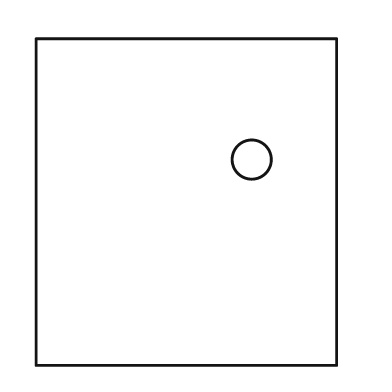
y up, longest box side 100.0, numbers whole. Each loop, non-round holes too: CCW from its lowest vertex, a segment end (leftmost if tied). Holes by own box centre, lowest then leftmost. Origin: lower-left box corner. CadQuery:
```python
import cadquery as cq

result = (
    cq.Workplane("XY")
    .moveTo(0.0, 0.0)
    .lineTo(92.0, 0.0)
    .lineTo(92.0, 100.0)
    .lineTo(0.0, 100.0)
    .close()
    .moveTo(66.0, 63.0)
    .circle(6.0)
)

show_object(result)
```